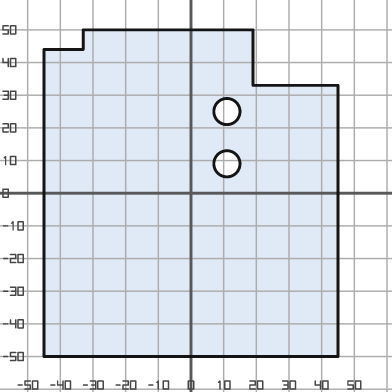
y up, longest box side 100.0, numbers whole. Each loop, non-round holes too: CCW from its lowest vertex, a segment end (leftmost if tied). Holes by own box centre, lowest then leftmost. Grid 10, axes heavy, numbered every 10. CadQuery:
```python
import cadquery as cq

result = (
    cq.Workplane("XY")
    .moveTo(-45.0, -50.0)
    .lineTo(45.0, -50.0)
    .lineTo(45.0, 33.0)
    .lineTo(19.0, 33.0)
    .lineTo(19.0, 50.0)
    .lineTo(-33.0, 50.0)
    .lineTo(-33.0, 44.0)
    .lineTo(-45.0, 44.0)
    .close()
    .moveTo(11.0, 9.0)
    .circle(4.0)
    .moveTo(11.0, 25.0)
    .circle(4.0)
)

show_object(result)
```